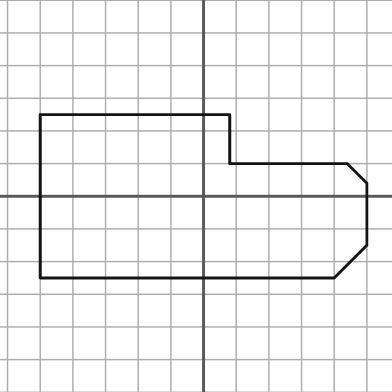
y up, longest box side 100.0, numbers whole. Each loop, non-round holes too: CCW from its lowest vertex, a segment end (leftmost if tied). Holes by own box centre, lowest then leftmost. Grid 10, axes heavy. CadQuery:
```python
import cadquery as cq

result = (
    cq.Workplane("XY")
    .moveTo(-50.0, -25.0)
    .lineTo(40.0, -25.0)
    .lineTo(50.0, -15.0)
    .lineTo(50.0, 4.0)
    .lineTo(44.0, 10.0)
    .lineTo(8.0, 10.0)
    .lineTo(8.0, 25.0)
    .lineTo(-50.0, 25.0)
    .close()
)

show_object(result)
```